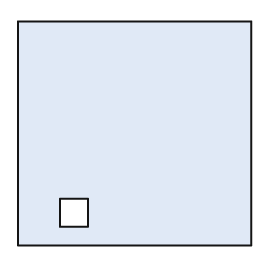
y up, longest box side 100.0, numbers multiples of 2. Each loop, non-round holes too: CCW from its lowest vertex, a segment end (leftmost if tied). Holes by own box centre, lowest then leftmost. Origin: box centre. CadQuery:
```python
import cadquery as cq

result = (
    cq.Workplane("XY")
    .moveTo(-50.0, -48.0)
    .lineTo(50.0, -48.0)
    .lineTo(50.0, 48.0)
    .lineTo(-50.0, 48.0)
    .close()
    .moveTo(-32.0, -40.0)
    .lineTo(-20.0, -40.0)
    .lineTo(-20.0, -28.0)
    .lineTo(-32.0, -28.0)
    .close()
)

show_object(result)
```